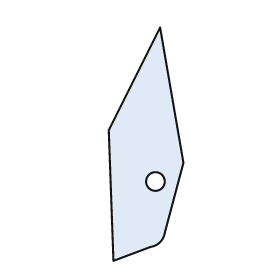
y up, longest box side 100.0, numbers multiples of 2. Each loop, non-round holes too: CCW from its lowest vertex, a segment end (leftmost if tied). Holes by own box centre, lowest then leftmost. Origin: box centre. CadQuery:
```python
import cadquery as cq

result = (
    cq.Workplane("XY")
    .moveTo(-14.0, -50.0)
    .lineTo(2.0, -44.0)
    .threePointArc((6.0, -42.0), (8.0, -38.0))
    .lineTo(16.0, -8.0)
    .lineTo(6.0, 50.0)
    .lineTo(-16.0, 6.0)
    .close()
    .moveTo(4.0, -16.0)
    .circle(4.0)
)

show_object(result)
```